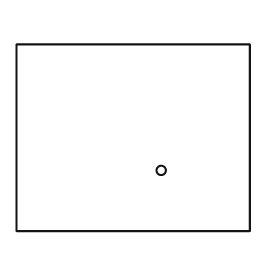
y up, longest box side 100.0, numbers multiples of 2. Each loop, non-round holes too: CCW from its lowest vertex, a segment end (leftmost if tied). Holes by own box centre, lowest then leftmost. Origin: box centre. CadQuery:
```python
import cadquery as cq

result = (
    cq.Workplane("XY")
    .moveTo(-50.0, -40.0)
    .lineTo(50.0, -40.0)
    .lineTo(50.0, 40.0)
    .lineTo(-50.0, 40.0)
    .close()
    .moveTo(12.0, -14.0)
    .circle(2.0)
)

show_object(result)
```